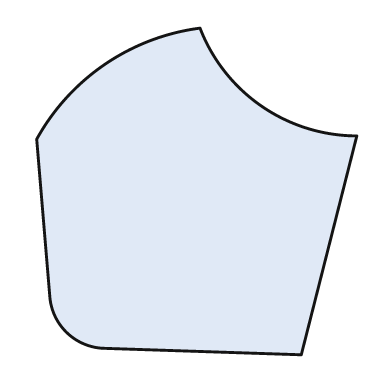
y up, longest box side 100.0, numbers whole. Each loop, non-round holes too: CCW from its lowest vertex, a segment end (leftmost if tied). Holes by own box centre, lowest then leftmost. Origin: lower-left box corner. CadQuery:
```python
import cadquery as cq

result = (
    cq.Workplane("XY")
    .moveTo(81.0, 0.0)
    .lineTo(98.0, 67.0)
    .threePointArc((69.0, 76.0), (50.0, 100.0))
    .threePointArc((21.0, 89.0), (0.0, 66.0))
    .lineTo(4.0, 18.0)
    .threePointArc((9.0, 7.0), (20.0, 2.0))
    .close()
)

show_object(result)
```